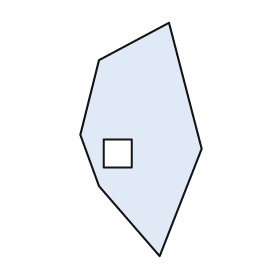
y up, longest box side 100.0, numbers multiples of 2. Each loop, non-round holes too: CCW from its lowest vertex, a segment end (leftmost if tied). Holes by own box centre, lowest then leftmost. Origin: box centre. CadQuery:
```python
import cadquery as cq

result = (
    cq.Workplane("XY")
    .moveTo(8.0, -50.0)
    .lineTo(26.0, -4.0)
    .lineTo(12.0, 50.0)
    .lineTo(-18.0, 34.0)
    .lineTo(-26.0, 2.0)
    .lineTo(-18.0, -20.0)
    .close()
    .moveTo(-16.0, -12.0)
    .lineTo(-4.0, -12.0)
    .lineTo(-4.0, 0.0)
    .lineTo(-16.0, 0.0)
    .close()
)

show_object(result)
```